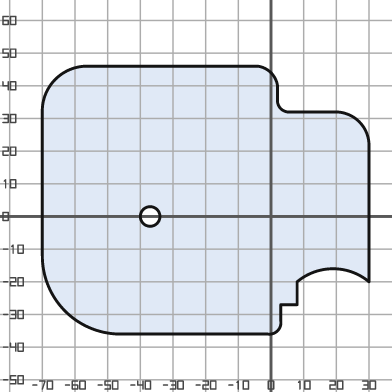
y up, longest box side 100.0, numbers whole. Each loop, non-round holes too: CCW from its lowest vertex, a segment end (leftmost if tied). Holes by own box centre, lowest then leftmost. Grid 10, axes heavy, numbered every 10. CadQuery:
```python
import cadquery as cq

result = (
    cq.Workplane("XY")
    .moveTo(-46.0, -36.0)
    .lineTo(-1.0, -36.0)
    .threePointArc((2.0, -35.0), (3.0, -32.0))
    .lineTo(3.0, -27.0)
    .lineTo(8.0, -27.0)
    .lineTo(8.0, -20.0)
    .threePointArc((19.0, -16.0), (30.0, -20.0))
    .lineTo(30.0, 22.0)
    .threePointArc((27.0, 29.0), (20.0, 32.0))
    .lineTo(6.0, 32.0)
    .threePointArc((3.0, 33.0), (2.0, 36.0))
    .lineTo(2.0, 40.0)
    .threePointArc((0.0, 44.0), (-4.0, 46.0))
    .lineTo(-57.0, 46.0)
    .threePointArc((-66.0, 42.0), (-70.0, 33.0))
    .lineTo(-70.0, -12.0)
    .threePointArc((-63.0, -29.0), (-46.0, -36.0))
    .close()
    .moveTo(-37.0, 0.0)
    .circle(3.0)
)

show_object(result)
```